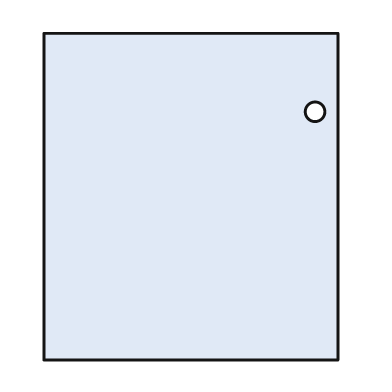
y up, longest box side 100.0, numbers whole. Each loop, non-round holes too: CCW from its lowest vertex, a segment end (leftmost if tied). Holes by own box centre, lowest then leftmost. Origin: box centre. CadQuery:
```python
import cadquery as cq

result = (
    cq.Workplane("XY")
    .moveTo(-45.0, -50.0)
    .lineTo(45.0, -50.0)
    .lineTo(45.0, 50.0)
    .lineTo(-45.0, 50.0)
    .close()
    .moveTo(38.0, 26.0)
    .circle(3.0)
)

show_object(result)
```